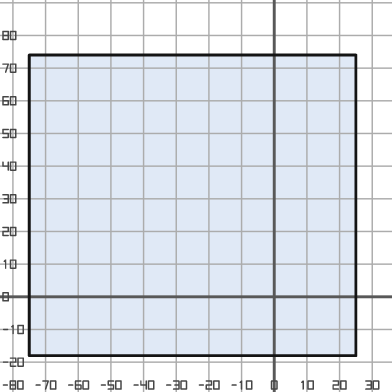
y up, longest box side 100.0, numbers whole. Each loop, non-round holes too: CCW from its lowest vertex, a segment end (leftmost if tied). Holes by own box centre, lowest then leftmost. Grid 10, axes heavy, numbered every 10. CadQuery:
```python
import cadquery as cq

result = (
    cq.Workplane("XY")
    .moveTo(-75.0, -18.0)
    .lineTo(25.0, -18.0)
    .lineTo(25.0, 74.0)
    .lineTo(-75.0, 74.0)
    .close()
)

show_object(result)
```